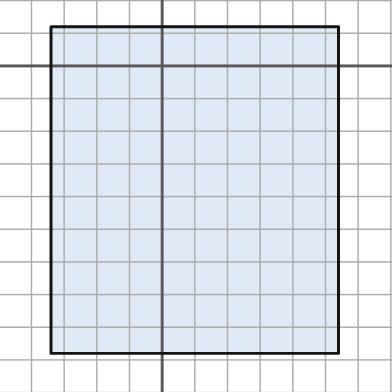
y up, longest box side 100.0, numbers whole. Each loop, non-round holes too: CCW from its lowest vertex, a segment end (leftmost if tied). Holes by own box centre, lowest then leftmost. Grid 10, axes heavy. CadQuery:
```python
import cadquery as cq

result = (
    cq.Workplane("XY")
    .moveTo(-34.0, -88.0)
    .lineTo(54.0, -88.0)
    .lineTo(54.0, 12.0)
    .lineTo(-34.0, 12.0)
    .close()
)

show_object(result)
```